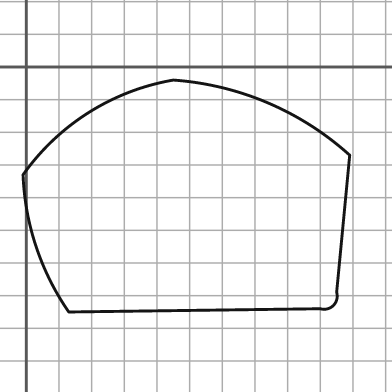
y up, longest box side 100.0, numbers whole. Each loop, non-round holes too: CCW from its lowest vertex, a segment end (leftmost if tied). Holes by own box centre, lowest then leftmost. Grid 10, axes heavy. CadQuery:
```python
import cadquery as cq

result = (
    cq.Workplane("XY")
    .moveTo(13.0, -75.0)
    .lineTo(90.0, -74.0)
    .threePointArc((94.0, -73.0), (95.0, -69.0))
    .lineTo(99.0, -27.0)
    .threePointArc((74.0, -11.0), (45.0, -4.0))
    .threePointArc((19.0, -14.0), (-1.0, -33.0))
    .threePointArc((3.0, -55.0), (13.0, -75.0))
    .close()
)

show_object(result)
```